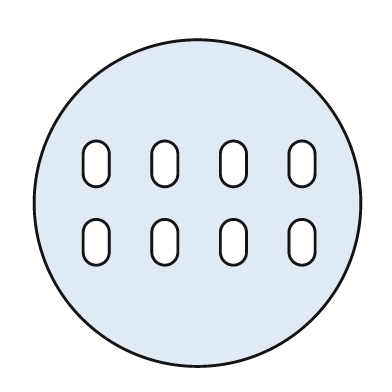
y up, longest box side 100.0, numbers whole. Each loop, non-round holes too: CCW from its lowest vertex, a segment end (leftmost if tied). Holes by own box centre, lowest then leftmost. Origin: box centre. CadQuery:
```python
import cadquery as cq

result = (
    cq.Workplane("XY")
    .moveTo(0.0, 0.0)
    .circle(50.0)
    .moveTo(-35.0, -15.0)
    .threePointArc((-31.0, -19.0), (-27.0, -15.0))
    .lineTo(-27.0, -9.0)
    .threePointArc((-31.0, -5.0), (-35.0, -9.0))
    .close()
    .moveTo(-14.0, -15.0)
    .threePointArc((-10.0, -19.0), (-6.0, -15.0))
    .lineTo(-6.0, -9.0)
    .threePointArc((-10.0, -5.0), (-14.0, -9.0))
    .close()
    .moveTo(7.0, -15.0)
    .threePointArc((11.0, -19.0), (15.0, -15.0))
    .lineTo(15.0, -9.0)
    .threePointArc((11.0, -5.0), (7.0, -9.0))
    .close()
    .moveTo(28.0, -15.0)
    .threePointArc((32.0, -19.0), (36.0, -15.0))
    .lineTo(36.0, -9.0)
    .threePointArc((32.0, -5.0), (28.0, -9.0))
    .close()
    .moveTo(-35.0, 9.0)
    .threePointArc((-31.0, 5.0), (-27.0, 9.0))
    .lineTo(-27.0, 15.0)
    .threePointArc((-31.0, 19.0), (-35.0, 15.0))
    .close()
    .moveTo(-14.0, 9.0)
    .threePointArc((-10.0, 5.0), (-6.0, 9.0))
    .lineTo(-6.0, 15.0)
    .threePointArc((-10.0, 19.0), (-14.0, 15.0))
    .close()
    .moveTo(7.0, 9.0)
    .threePointArc((11.0, 5.0), (15.0, 9.0))
    .lineTo(15.0, 15.0)
    .threePointArc((11.0, 19.0), (7.0, 15.0))
    .close()
    .moveTo(28.0, 9.0)
    .threePointArc((32.0, 5.0), (36.0, 9.0))
    .lineTo(36.0, 15.0)
    .threePointArc((32.0, 19.0), (28.0, 15.0))
    .close()
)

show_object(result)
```